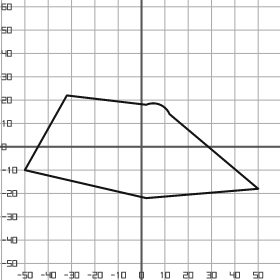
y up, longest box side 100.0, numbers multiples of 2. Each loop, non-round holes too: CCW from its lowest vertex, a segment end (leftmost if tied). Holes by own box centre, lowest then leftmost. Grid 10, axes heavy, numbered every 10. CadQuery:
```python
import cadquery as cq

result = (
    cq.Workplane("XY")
    .moveTo(2.0, -22.0)
    .lineTo(50.0, -18.0)
    .lineTo(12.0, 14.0)
    .threePointArc((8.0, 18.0), (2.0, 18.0))
    .lineTo(-32.0, 22.0)
    .lineTo(-50.0, -10.0)
    .close()
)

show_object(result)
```